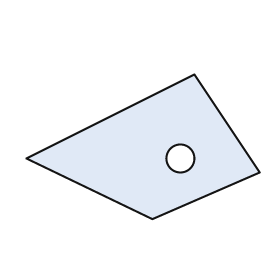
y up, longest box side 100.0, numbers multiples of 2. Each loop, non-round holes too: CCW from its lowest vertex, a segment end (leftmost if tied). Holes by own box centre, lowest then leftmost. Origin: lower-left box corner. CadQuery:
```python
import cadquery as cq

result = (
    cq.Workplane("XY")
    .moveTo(54.0, 0.0)
    .lineTo(100.0, 20.0)
    .lineTo(72.0, 62.0)
    .lineTo(0.0, 26.0)
    .close()
    .moveTo(66.0, 26.0)
    .circle(6.0)
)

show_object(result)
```